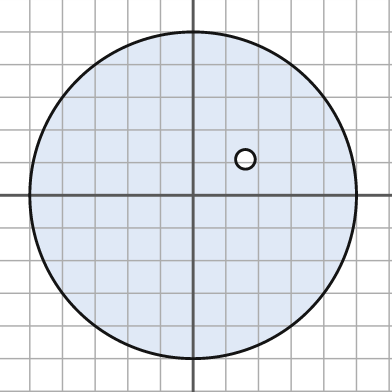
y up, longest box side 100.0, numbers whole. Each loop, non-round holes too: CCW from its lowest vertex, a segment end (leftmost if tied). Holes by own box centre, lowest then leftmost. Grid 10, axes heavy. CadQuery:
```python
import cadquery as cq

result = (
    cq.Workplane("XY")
    .moveTo(0.0, 0.0)
    .circle(50.0)
    .moveTo(16.0, 11.0)
    .circle(3.0)
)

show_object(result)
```